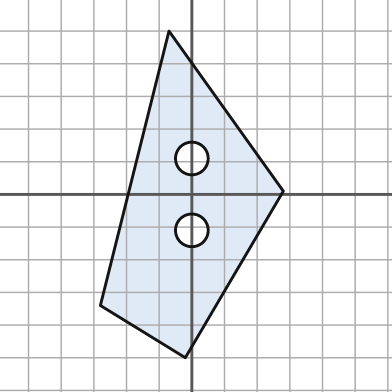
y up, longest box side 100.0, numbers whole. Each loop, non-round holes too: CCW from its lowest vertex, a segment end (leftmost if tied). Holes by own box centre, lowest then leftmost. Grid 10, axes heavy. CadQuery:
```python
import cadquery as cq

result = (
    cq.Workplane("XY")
    .moveTo(-2.0, -50.0)
    .lineTo(28.0, 1.0)
    .lineTo(-7.0, 50.0)
    .lineTo(-28.0, -34.0)
    .close()
    .moveTo(0.0, -11.0)
    .circle(5.0)
    .moveTo(0.0, 11.0)
    .circle(5.0)
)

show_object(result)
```